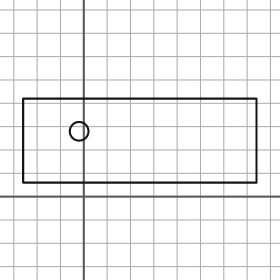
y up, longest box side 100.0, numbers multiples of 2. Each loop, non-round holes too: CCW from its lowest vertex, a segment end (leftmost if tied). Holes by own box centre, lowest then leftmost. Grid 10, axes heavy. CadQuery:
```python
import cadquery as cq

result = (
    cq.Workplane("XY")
    .moveTo(-26.0, 6.0)
    .lineTo(74.0, 6.0)
    .lineTo(74.0, 42.0)
    .lineTo(-26.0, 42.0)
    .close()
    .moveTo(-2.0, 28.0)
    .circle(4.0)
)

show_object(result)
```